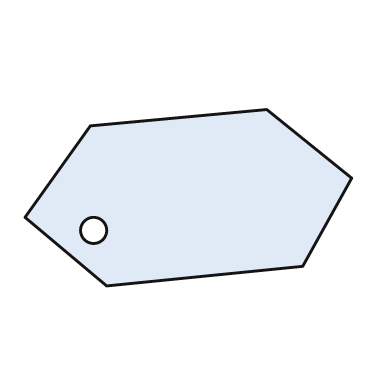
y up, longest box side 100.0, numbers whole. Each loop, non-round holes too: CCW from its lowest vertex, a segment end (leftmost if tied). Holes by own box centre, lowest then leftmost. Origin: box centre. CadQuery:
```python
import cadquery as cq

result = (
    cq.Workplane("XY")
    .moveTo(-25.0, -27.0)
    .lineTo(35.0, -21.0)
    .lineTo(50.0, 6.0)
    .lineTo(24.0, 27.0)
    .lineTo(-30.0, 22.0)
    .lineTo(-50.0, -6.0)
    .close()
    .moveTo(-29.0, -10.0)
    .circle(4.0)
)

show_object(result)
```